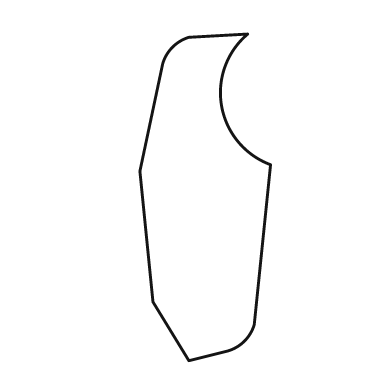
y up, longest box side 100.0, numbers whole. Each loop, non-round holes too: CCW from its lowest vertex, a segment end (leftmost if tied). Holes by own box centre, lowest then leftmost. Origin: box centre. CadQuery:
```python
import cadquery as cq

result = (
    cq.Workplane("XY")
    .moveTo(-5.0, -50.0)
    .lineTo(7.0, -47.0)
    .threePointArc((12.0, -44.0), (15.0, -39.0))
    .lineTo(20.0, 10.0)
    .threePointArc((5.0, 28.0), (13.0, 50.0))
    .lineTo(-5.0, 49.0)
    .threePointArc((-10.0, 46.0), (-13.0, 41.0))
    .lineTo(-20.0, 8.0)
    .lineTo(-16.0, -32.0)
    .close()
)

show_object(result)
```